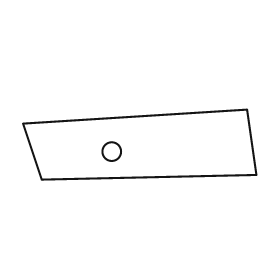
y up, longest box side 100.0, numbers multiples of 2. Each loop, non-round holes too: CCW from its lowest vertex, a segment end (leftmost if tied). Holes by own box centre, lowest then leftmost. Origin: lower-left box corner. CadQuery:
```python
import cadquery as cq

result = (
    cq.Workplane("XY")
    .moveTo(8.0, 0.0)
    .lineTo(100.0, 2.0)
    .lineTo(96.0, 30.0)
    .lineTo(0.0, 24.0)
    .close()
    .moveTo(38.0, 12.0)
    .circle(4.0)
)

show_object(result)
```